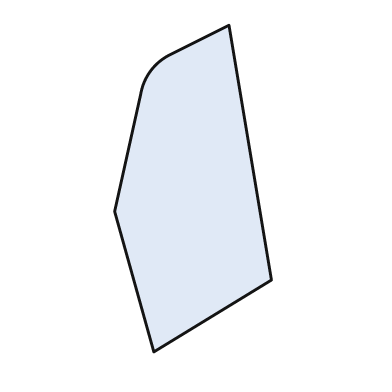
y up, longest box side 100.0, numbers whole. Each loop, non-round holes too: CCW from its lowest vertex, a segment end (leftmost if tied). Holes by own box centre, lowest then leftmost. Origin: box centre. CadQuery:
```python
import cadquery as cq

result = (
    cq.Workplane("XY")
    .moveTo(-12.0, -50.0)
    .lineTo(24.0, -28.0)
    .lineTo(11.0, 50.0)
    .lineTo(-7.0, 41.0)
    .threePointArc((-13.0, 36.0), (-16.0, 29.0))
    .lineTo(-24.0, -7.0)
    .close()
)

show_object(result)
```